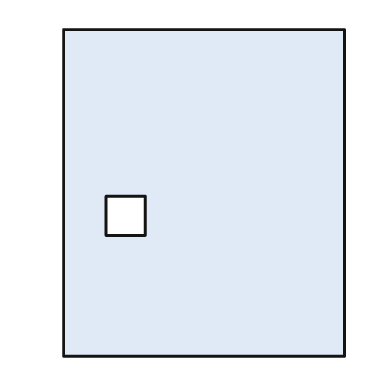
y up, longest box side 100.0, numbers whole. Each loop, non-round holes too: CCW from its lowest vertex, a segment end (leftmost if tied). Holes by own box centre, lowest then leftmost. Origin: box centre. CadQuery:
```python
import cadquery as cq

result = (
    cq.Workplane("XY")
    .moveTo(-43.0, -50.0)
    .lineTo(43.0, -50.0)
    .lineTo(43.0, 50.0)
    .lineTo(-43.0, 50.0)
    .close()
    .moveTo(-30.0, -13.0)
    .lineTo(-18.0, -13.0)
    .lineTo(-18.0, -1.0)
    .lineTo(-30.0, -1.0)
    .close()
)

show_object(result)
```